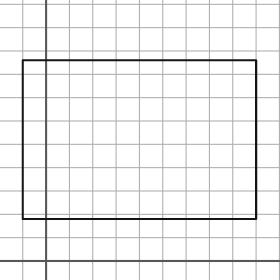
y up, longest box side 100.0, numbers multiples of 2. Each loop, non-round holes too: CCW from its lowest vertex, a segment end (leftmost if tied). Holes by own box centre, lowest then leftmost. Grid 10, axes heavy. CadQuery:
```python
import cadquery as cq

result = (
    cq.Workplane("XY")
    .moveTo(-10.0, 18.0)
    .lineTo(90.0, 18.0)
    .lineTo(90.0, 86.0)
    .lineTo(-10.0, 86.0)
    .close()
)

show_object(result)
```